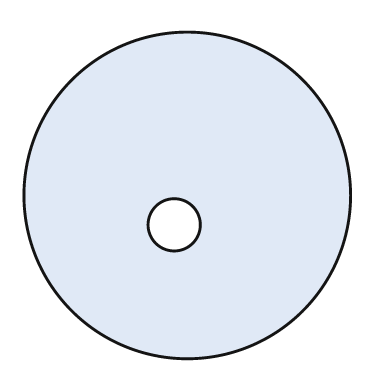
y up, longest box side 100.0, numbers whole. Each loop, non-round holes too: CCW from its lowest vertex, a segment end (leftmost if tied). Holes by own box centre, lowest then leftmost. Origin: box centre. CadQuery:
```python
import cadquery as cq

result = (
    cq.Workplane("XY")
    .moveTo(0.0, 0.0)
    .circle(50.0)
    .moveTo(-4.0, -9.0)
    .circle(8.0)
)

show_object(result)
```